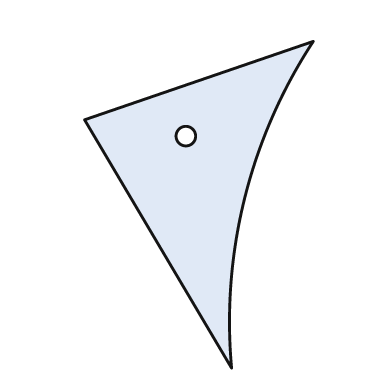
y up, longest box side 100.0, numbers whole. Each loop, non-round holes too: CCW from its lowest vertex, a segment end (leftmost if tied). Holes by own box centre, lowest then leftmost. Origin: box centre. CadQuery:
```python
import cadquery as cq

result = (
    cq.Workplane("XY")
    .moveTo(10.0, -50.0)
    .threePointArc((14.0, 2.0), (35.0, 50.0))
    .lineTo(-35.0, 26.0)
    .close()
    .moveTo(-4.0, 21.0)
    .circle(3.0)
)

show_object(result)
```